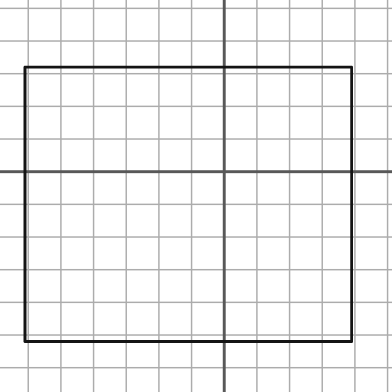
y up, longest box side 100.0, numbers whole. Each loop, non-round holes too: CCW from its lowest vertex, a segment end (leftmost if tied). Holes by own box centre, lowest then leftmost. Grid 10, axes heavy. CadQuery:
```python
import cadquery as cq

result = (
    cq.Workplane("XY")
    .moveTo(-61.0, -52.0)
    .lineTo(39.0, -52.0)
    .lineTo(39.0, 32.0)
    .lineTo(-61.0, 32.0)
    .close()
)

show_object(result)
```